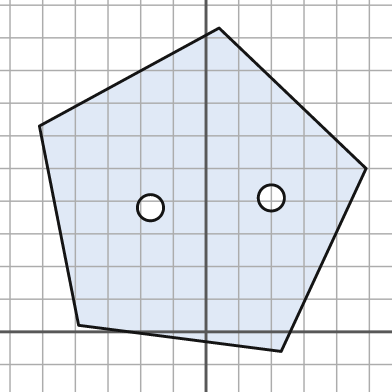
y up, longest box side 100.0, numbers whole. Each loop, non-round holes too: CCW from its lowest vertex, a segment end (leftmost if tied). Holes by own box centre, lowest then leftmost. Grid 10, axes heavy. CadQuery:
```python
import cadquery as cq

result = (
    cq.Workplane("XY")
    .moveTo(23.0, -6.0)
    .lineTo(49.0, 50.0)
    .lineTo(4.0, 93.0)
    .lineTo(-51.0, 63.0)
    .lineTo(-39.0, 2.0)
    .close()
    .moveTo(-17.0, 38.0)
    .circle(4.0)
    .moveTo(20.0, 41.0)
    .circle(4.0)
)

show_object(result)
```